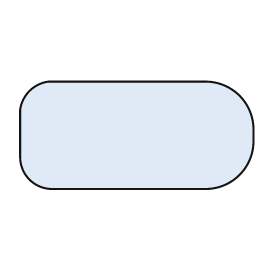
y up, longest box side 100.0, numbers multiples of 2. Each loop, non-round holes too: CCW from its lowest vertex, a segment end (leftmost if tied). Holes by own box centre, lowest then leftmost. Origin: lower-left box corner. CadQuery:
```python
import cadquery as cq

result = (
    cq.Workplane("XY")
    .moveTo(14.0, 0.0)
    .lineTo(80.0, 0.0)
    .threePointArc((94.0, 6.0), (100.0, 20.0))
    .lineTo(100.0, 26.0)
    .threePointArc((94.0, 40.0), (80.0, 46.0))
    .lineTo(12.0, 46.0)
    .threePointArc((4.0, 42.0), (0.0, 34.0))
    .lineTo(0.0, 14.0)
    .threePointArc((4.0, 4.0), (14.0, 0.0))
    .close()
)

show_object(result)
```